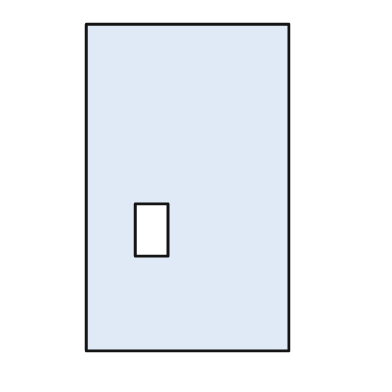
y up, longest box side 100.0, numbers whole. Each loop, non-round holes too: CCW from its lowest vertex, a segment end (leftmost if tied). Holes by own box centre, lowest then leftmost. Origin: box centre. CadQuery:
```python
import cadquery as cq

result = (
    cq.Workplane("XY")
    .moveTo(-31.0, -50.0)
    .lineTo(31.0, -50.0)
    .lineTo(31.0, 50.0)
    .lineTo(-31.0, 50.0)
    .close()
    .moveTo(-16.0, -21.0)
    .lineTo(-6.0, -21.0)
    .lineTo(-6.0, -5.0)
    .lineTo(-16.0, -5.0)
    .close()
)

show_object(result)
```